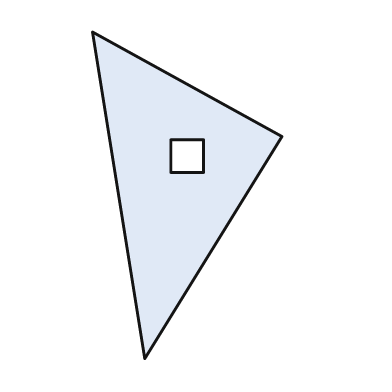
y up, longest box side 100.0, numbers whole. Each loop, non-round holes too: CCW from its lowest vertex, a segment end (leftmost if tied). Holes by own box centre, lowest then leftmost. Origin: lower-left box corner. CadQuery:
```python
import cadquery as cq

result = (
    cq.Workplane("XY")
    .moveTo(16.0, 0.0)
    .lineTo(58.0, 68.0)
    .lineTo(0.0, 100.0)
    .close()
    .moveTo(24.0, 57.0)
    .lineTo(34.0, 57.0)
    .lineTo(34.0, 67.0)
    .lineTo(24.0, 67.0)
    .close()
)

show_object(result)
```